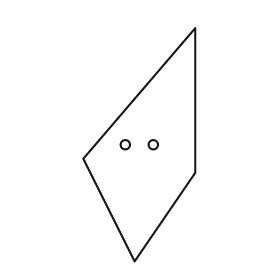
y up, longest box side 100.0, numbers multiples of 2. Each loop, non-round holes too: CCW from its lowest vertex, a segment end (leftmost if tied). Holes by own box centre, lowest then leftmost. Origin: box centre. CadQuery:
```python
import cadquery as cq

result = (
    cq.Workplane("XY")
    .moveTo(-2.0, -50.0)
    .lineTo(24.0, -12.0)
    .lineTo(24.0, 50.0)
    .lineTo(-24.0, -6.0)
    .close()
    .moveTo(-6.0, 0.0)
    .circle(2.0)
    .moveTo(6.0, 0.0)
    .circle(2.0)
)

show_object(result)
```